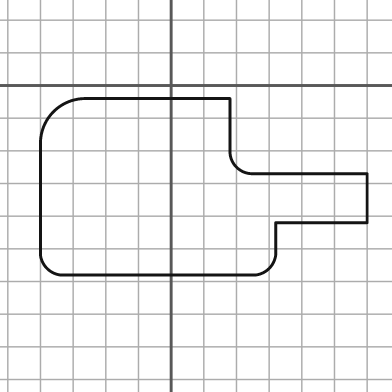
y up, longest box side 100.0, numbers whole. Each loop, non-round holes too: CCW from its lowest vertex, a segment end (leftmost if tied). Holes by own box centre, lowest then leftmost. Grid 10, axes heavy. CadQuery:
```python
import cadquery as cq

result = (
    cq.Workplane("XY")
    .moveTo(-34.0, -58.0)
    .lineTo(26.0, -58.0)
    .threePointArc((30.0, -56.0), (32.0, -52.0))
    .lineTo(32.0, -42.0)
    .lineTo(60.0, -42.0)
    .lineTo(60.0, -27.0)
    .lineTo(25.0, -27.0)
    .threePointArc((20.0, -25.0), (18.0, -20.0))
    .lineTo(18.0, -4.0)
    .lineTo(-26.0, -4.0)
    .threePointArc((-36.0, -8.0), (-40.0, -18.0))
    .lineTo(-40.0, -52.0)
    .threePointArc((-38.0, -56.0), (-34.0, -58.0))
    .close()
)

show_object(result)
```